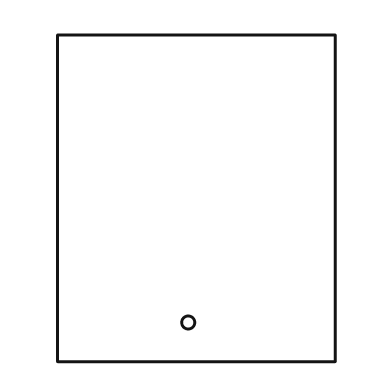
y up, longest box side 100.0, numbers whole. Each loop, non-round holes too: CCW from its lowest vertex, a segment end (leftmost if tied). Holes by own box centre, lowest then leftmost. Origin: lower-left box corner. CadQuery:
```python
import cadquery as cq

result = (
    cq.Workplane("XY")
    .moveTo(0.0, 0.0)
    .lineTo(85.0, 0.0)
    .lineTo(85.0, 100.0)
    .lineTo(0.0, 100.0)
    .close()
    .moveTo(40.0, 12.0)
    .circle(2.0)
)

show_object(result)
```